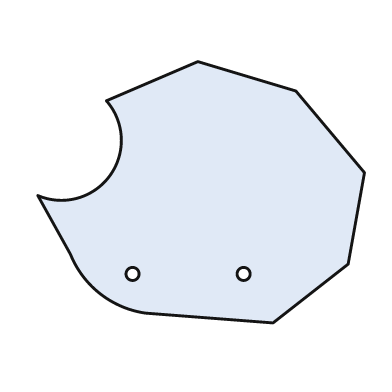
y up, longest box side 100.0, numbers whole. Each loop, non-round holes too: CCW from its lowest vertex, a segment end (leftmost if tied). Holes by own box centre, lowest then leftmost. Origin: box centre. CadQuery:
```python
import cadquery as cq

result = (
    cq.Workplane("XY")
    .moveTo(22.0, -40.0)
    .lineTo(45.0, -22.0)
    .lineTo(50.0, 6.0)
    .lineTo(29.0, 31.0)
    .lineTo(-1.0, 40.0)
    .lineTo(-29.0, 28.0)
    .threePointArc((-28.0, 5.0), (-50.0, -1.0))
    .lineTo(-40.0, -19.0)
    .threePointArc((-31.0, -31.0), (-17.0, -37.0))
    .close()
    .moveTo(-21.0, -25.0)
    .circle(2.0)
    .moveTo(13.0, -25.0)
    .circle(2.0)
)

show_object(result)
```